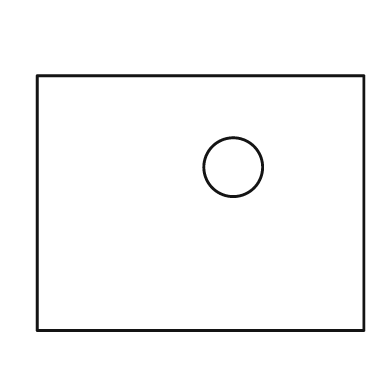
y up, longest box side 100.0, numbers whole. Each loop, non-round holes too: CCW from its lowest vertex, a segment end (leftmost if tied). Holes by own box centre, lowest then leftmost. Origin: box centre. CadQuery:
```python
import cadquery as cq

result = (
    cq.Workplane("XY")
    .moveTo(-50.0, -39.0)
    .lineTo(50.0, -39.0)
    .lineTo(50.0, 39.0)
    .lineTo(-50.0, 39.0)
    .close()
    .moveTo(10.0, 11.0)
    .circle(9.0)
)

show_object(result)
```